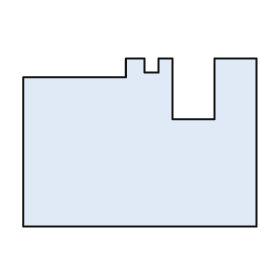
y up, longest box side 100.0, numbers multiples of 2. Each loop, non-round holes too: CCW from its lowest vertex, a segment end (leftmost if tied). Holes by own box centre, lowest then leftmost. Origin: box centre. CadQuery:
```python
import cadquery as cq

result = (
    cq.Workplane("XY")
    .moveTo(-50.0, -36.0)
    .lineTo(50.0, -36.0)
    .lineTo(50.0, 36.0)
    .lineTo(32.0, 36.0)
    .lineTo(32.0, 10.0)
    .lineTo(14.0, 10.0)
    .lineTo(14.0, 36.0)
    .lineTo(8.0, 36.0)
    .lineTo(8.0, 30.0)
    .lineTo(2.0, 30.0)
    .lineTo(2.0, 36.0)
    .lineTo(-6.0, 36.0)
    .lineTo(-6.0, 28.0)
    .lineTo(-50.0, 28.0)
    .close()
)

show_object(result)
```